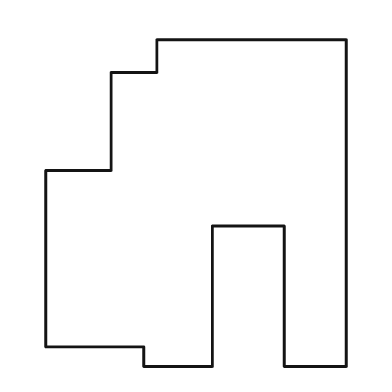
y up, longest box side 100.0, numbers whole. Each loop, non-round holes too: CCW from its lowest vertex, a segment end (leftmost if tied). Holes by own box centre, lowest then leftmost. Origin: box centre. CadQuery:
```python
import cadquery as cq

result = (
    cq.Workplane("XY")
    .moveTo(-16.0, -50.0)
    .lineTo(5.0, -50.0)
    .lineTo(5.0, -7.0)
    .lineTo(27.0, -7.0)
    .lineTo(27.0, -50.0)
    .lineTo(46.0, -50.0)
    .lineTo(46.0, 50.0)
    .lineTo(-12.0, 50.0)
    .lineTo(-12.0, 40.0)
    .lineTo(-26.0, 40.0)
    .lineTo(-26.0, 10.0)
    .lineTo(-46.0, 10.0)
    .lineTo(-46.0, -44.0)
    .lineTo(-16.0, -44.0)
    .close()
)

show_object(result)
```